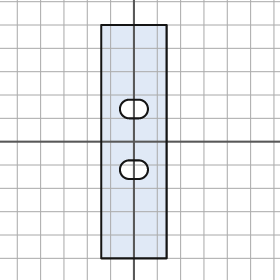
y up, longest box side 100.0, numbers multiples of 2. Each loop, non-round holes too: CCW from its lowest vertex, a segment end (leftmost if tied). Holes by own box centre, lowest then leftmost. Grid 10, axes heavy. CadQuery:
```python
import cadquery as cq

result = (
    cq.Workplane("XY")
    .moveTo(-14.0, -50.0)
    .lineTo(14.0, -50.0)
    .lineTo(14.0, 50.0)
    .lineTo(-14.0, 50.0)
    .close()
    .moveTo(-2.0, -16.0)
    .lineTo(2.0, -16.0)
    .threePointArc((6.0, -12.0), (2.0, -8.0))
    .lineTo(-2.0, -8.0)
    .threePointArc((-6.0, -12.0), (-2.0, -16.0))
    .close()
    .moveTo(-2.0, 10.0)
    .lineTo(2.0, 10.0)
    .threePointArc((6.0, 14.0), (2.0, 18.0))
    .lineTo(-2.0, 18.0)
    .threePointArc((-6.0, 14.0), (-2.0, 10.0))
    .close()
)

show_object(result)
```